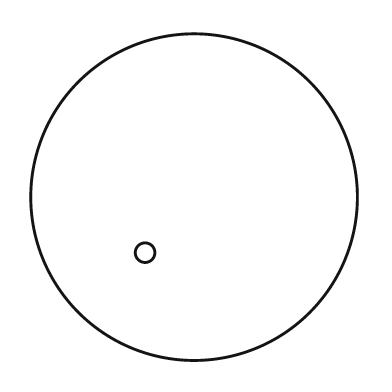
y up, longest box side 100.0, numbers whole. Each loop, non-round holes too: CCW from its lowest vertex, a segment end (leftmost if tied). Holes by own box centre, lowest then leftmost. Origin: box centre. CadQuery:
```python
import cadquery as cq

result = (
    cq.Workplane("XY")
    .moveTo(0.0, 0.0)
    .circle(50.0)
    .moveTo(-15.0, -17.0)
    .circle(3.0)
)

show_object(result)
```